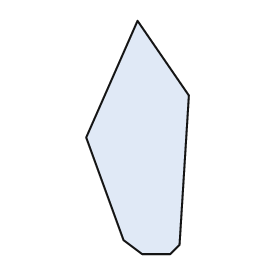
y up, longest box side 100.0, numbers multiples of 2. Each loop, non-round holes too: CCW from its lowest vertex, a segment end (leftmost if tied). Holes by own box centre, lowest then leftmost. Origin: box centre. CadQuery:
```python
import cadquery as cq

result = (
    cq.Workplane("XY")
    .moveTo(2.0, -50.0)
    .lineTo(14.0, -50.0)
    .lineTo(18.0, -46.0)
    .lineTo(22.0, 18.0)
    .lineTo(0.0, 50.0)
    .lineTo(-22.0, 0.0)
    .lineTo(-6.0, -44.0)
    .close()
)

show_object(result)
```